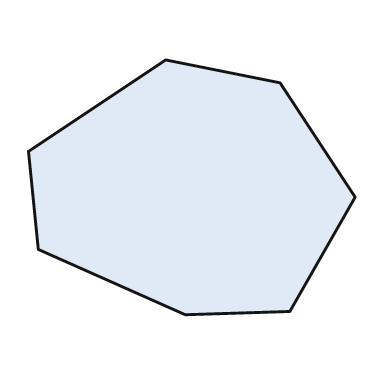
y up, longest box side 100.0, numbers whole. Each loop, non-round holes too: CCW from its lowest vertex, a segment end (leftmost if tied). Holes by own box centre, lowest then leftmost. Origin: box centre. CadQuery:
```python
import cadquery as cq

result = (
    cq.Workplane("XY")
    .moveTo(-2.0, -39.0)
    .lineTo(30.0, -38.0)
    .lineTo(50.0, -3.0)
    .lineTo(27.0, 32.0)
    .lineTo(-8.0, 39.0)
    .lineTo(-50.0, 11.0)
    .lineTo(-47.0, -19.0)
    .close()
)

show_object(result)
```